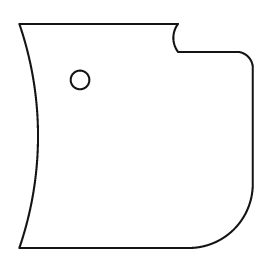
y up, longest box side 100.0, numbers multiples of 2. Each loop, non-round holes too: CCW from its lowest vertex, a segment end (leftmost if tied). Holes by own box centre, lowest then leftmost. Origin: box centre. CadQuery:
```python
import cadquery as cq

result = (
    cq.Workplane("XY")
    .moveTo(-50.0, -48.0)
    .lineTo(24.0, -48.0)
    .threePointArc((42.0, -40.0), (50.0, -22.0))
    .lineTo(50.0, 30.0)
    .threePointArc((48.0, 34.0), (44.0, 36.0))
    .lineTo(18.0, 36.0)
    .threePointArc((16.0, 42.0), (18.0, 48.0))
    .lineTo(-50.0, 48.0)
    .threePointArc((-42.0, 0.0), (-50.0, -48.0))
    .close()
    .moveTo(-24.0, 24.0)
    .circle(4.0)
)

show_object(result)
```